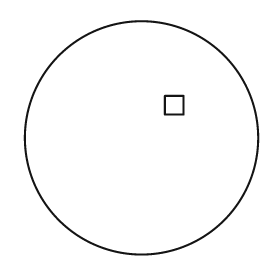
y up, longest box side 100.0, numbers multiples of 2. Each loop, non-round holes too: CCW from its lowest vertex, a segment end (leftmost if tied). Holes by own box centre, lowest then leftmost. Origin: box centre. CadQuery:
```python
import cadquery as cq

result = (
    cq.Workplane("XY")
    .moveTo(0.0, 0.0)
    .circle(50.0)
    .moveTo(10.0, 10.0)
    .lineTo(18.0, 10.0)
    .lineTo(18.0, 18.0)
    .lineTo(10.0, 18.0)
    .close()
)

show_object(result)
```